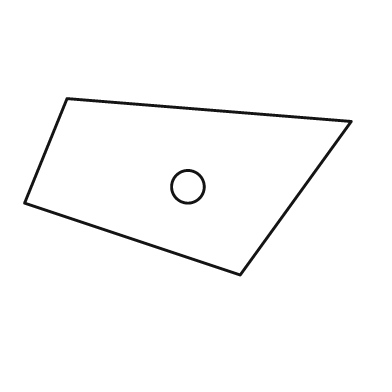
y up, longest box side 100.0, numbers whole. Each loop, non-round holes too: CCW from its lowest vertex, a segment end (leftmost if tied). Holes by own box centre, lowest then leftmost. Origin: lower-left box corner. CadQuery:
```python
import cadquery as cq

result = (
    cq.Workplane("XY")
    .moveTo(66.0, 0.0)
    .lineTo(100.0, 47.0)
    .lineTo(13.0, 54.0)
    .lineTo(0.0, 22.0)
    .close()
    .moveTo(50.0, 27.0)
    .circle(5.0)
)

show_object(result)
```